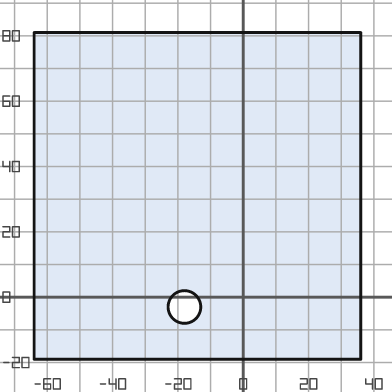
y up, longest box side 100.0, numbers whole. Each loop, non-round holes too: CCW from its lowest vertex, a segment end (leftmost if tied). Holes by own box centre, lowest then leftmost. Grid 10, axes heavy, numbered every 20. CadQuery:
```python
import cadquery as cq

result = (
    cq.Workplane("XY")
    .moveTo(-64.0, -19.0)
    .lineTo(36.0, -19.0)
    .lineTo(36.0, 81.0)
    .lineTo(-64.0, 81.0)
    .close()
    .moveTo(-18.0, -3.0)
    .circle(5.0)
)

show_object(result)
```